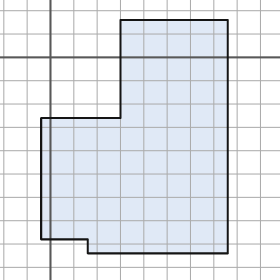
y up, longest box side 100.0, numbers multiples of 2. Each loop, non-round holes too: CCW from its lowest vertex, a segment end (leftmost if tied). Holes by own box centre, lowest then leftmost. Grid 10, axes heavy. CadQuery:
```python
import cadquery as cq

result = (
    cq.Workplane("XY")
    .moveTo(16.0, -84.0)
    .lineTo(76.0, -84.0)
    .lineTo(76.0, 16.0)
    .lineTo(30.0, 16.0)
    .lineTo(30.0, -26.0)
    .lineTo(-4.0, -26.0)
    .lineTo(-4.0, -78.0)
    .lineTo(16.0, -78.0)
    .close()
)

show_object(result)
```